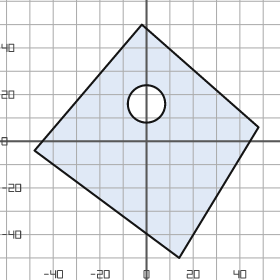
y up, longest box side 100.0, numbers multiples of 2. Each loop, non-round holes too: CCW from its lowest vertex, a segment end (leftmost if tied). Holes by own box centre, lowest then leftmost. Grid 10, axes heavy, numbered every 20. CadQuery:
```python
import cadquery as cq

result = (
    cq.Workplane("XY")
    .moveTo(14.0, -50.0)
    .lineTo(48.0, 6.0)
    .lineTo(-2.0, 50.0)
    .lineTo(-48.0, -4.0)
    .close()
    .moveTo(0.0, 16.0)
    .circle(8.0)
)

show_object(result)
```